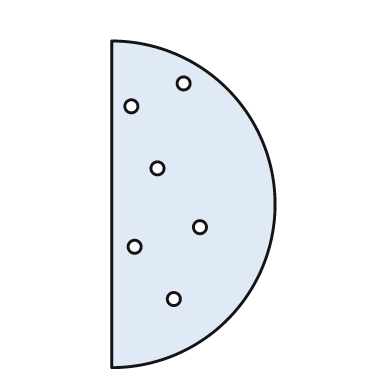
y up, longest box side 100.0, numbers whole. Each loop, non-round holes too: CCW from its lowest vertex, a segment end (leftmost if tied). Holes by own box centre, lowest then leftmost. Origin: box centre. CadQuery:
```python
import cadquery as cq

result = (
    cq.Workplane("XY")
    .moveTo(-25.0, -50.0)
    .threePointArc((25.0, 0.0), (-25.0, 50.0))
    .close()
    .moveTo(-6.0, -29.0)
    .circle(2.0)
    .moveTo(-18.0, -13.0)
    .circle(2.0)
    .moveTo(2.0, -7.0)
    .circle(2.0)
    .moveTo(-11.0, 11.0)
    .circle(2.0)
    .moveTo(-19.0, 30.0)
    .circle(2.0)
    .moveTo(-3.0, 37.0)
    .circle(2.0)
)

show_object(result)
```